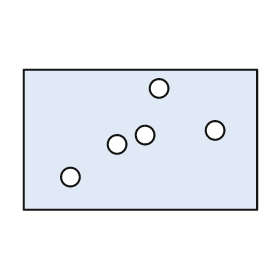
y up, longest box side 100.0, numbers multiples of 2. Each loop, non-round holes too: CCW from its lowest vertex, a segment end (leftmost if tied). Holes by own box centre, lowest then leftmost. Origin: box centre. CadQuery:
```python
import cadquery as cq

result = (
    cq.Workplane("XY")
    .moveTo(-50.0, -30.0)
    .lineTo(50.0, -30.0)
    .lineTo(50.0, 30.0)
    .lineTo(-50.0, 30.0)
    .close()
    .moveTo(-30.0, -16.0)
    .circle(4.0)
    .moveTo(-10.0, -2.0)
    .circle(4.0)
    .moveTo(2.0, 2.0)
    .circle(4.0)
    .moveTo(32.0, 4.0)
    .circle(4.0)
    .moveTo(8.0, 22.0)
    .circle(4.0)
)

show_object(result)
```